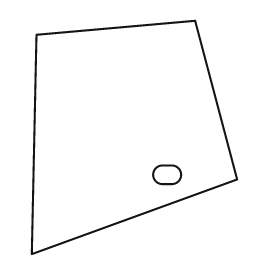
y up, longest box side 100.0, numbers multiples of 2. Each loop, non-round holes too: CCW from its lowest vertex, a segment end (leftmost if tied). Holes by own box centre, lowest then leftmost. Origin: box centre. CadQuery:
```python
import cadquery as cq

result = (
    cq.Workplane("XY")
    .moveTo(-44.0, -50.0)
    .lineTo(44.0, -18.0)
    .lineTo(26.0, 50.0)
    .lineTo(-42.0, 44.0)
    .close()
    .moveTo(12.0, -20.0)
    .lineTo(16.0, -20.0)
    .threePointArc((20.0, -16.0), (16.0, -12.0))
    .lineTo(12.0, -12.0)
    .threePointArc((8.0, -16.0), (12.0, -20.0))
    .close()
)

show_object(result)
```